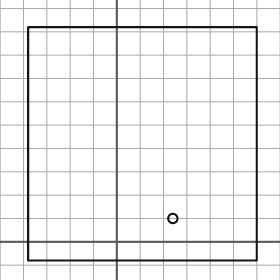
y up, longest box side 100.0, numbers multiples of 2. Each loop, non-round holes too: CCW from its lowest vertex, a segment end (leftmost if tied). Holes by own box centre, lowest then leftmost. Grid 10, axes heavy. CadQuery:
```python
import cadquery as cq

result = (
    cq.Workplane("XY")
    .moveTo(-38.0, -8.0)
    .lineTo(60.0, -8.0)
    .lineTo(60.0, 92.0)
    .lineTo(-38.0, 92.0)
    .close()
    .moveTo(24.0, 10.0)
    .circle(2.0)
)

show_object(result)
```